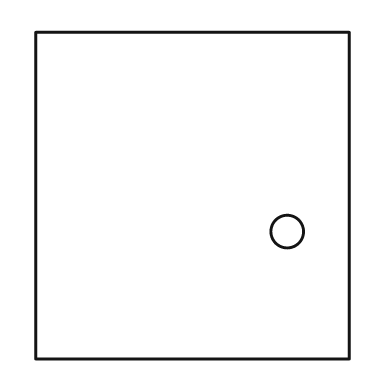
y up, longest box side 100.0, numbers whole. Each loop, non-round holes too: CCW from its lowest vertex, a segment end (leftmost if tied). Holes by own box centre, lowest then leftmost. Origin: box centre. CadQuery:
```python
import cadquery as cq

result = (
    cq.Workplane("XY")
    .moveTo(-48.0, -50.0)
    .lineTo(48.0, -50.0)
    .lineTo(48.0, 50.0)
    .lineTo(-48.0, 50.0)
    .close()
    .moveTo(29.0, -11.0)
    .circle(5.0)
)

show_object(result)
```